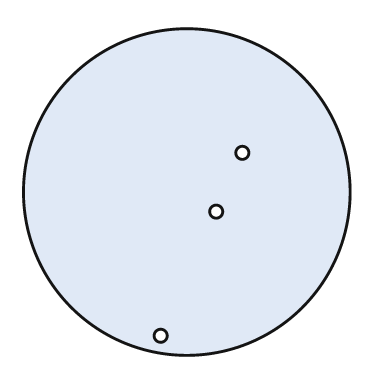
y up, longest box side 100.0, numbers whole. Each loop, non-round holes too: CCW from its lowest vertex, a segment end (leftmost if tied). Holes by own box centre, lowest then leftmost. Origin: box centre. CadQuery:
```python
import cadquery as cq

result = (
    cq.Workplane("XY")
    .moveTo(0.0, 0.0)
    .circle(50.0)
    .moveTo(-8.0, -44.0)
    .circle(2.0)
    .moveTo(9.0, -6.0)
    .circle(2.0)
    .moveTo(17.0, 12.0)
    .circle(2.0)
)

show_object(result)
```